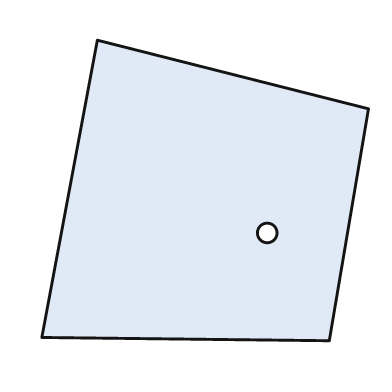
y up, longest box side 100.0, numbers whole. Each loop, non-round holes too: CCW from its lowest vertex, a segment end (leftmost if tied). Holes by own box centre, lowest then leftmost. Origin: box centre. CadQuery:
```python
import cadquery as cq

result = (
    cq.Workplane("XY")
    .moveTo(38.0, -46.0)
    .lineTo(50.0, 25.0)
    .lineTo(-33.0, 46.0)
    .lineTo(-50.0, -45.0)
    .close()
    .moveTo(19.0, -13.0)
    .circle(3.0)
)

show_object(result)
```